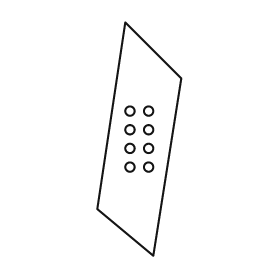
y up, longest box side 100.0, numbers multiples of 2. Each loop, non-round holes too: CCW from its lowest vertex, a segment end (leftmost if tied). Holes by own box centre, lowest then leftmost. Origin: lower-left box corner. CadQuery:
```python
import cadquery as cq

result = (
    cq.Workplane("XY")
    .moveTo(24.0, 0.0)
    .lineTo(36.0, 76.0)
    .lineTo(12.0, 100.0)
    .lineTo(0.0, 20.0)
    .close()
    .moveTo(14.0, 38.0)
    .circle(2.0)
    .moveTo(22.0, 38.0)
    .circle(2.0)
    .moveTo(14.0, 46.0)
    .circle(2.0)
    .moveTo(22.0, 46.0)
    .circle(2.0)
    .moveTo(14.0, 54.0)
    .circle(2.0)
    .moveTo(22.0, 54.0)
    .circle(2.0)
    .moveTo(14.0, 62.0)
    .circle(2.0)
    .moveTo(22.0, 62.0)
    .circle(2.0)
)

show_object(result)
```